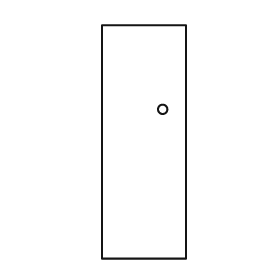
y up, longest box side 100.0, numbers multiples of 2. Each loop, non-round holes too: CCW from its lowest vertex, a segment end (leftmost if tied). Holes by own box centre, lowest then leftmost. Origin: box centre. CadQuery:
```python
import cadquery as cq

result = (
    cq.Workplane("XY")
    .moveTo(-18.0, -50.0)
    .lineTo(18.0, -50.0)
    .lineTo(18.0, 50.0)
    .lineTo(-18.0, 50.0)
    .close()
    .moveTo(8.0, 14.0)
    .circle(2.0)
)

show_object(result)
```